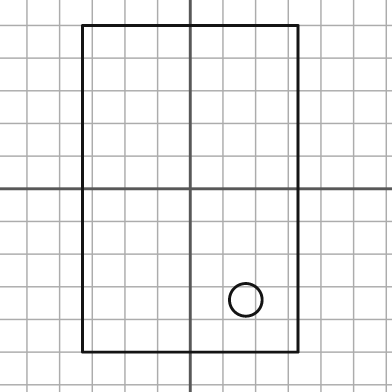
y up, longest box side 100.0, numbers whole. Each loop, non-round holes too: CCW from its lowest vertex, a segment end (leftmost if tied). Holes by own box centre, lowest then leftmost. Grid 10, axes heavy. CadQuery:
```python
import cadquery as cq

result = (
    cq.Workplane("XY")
    .moveTo(-33.0, -50.0)
    .lineTo(33.0, -50.0)
    .lineTo(33.0, 50.0)
    .lineTo(-33.0, 50.0)
    .close()
    .moveTo(17.0, -34.0)
    .circle(5.0)
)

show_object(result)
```